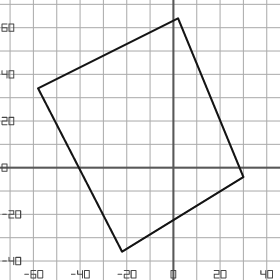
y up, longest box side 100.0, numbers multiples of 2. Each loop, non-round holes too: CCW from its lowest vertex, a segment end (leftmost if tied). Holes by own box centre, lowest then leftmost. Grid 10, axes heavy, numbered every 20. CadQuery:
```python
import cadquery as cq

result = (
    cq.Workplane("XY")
    .moveTo(-22.0, -36.0)
    .lineTo(30.0, -4.0)
    .lineTo(2.0, 64.0)
    .lineTo(-58.0, 34.0)
    .close()
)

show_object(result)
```